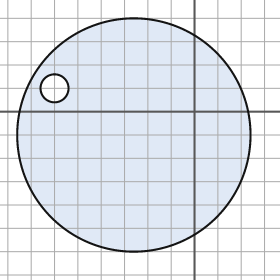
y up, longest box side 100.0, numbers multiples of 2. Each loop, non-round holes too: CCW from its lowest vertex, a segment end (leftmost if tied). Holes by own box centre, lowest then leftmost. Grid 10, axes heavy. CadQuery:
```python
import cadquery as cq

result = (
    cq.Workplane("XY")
    .moveTo(-26.0, -10.0)
    .circle(50.0)
    .moveTo(-60.0, 10.0)
    .circle(6.0)
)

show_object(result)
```